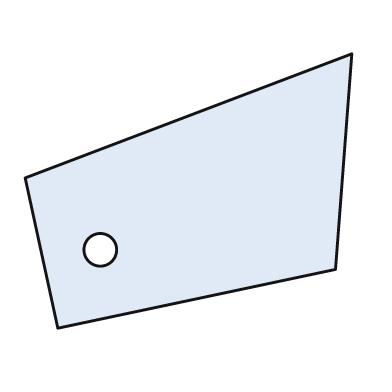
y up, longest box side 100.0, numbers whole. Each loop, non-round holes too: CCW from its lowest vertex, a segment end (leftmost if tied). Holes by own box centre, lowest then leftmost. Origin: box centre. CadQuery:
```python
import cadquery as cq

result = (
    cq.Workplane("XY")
    .moveTo(-40.0, -42.0)
    .lineTo(45.0, -24.0)
    .lineTo(50.0, 42.0)
    .lineTo(-50.0, 4.0)
    .close()
    .moveTo(-27.0, -18.0)
    .circle(5.0)
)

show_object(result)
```